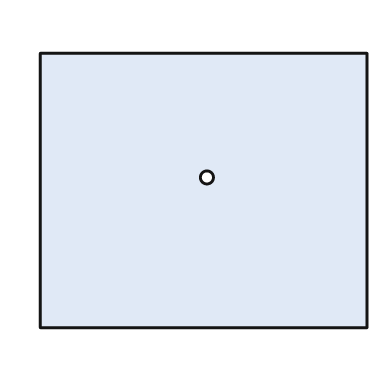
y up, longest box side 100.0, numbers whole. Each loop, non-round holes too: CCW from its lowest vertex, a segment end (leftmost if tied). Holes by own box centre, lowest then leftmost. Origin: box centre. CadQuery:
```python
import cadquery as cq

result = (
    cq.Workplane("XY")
    .moveTo(-50.0, -42.0)
    .lineTo(50.0, -42.0)
    .lineTo(50.0, 42.0)
    .lineTo(-50.0, 42.0)
    .close()
    .moveTo(1.0, 4.0)
    .circle(2.0)
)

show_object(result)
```